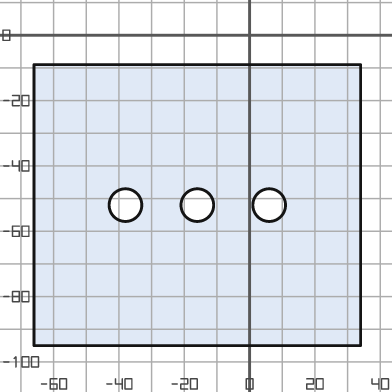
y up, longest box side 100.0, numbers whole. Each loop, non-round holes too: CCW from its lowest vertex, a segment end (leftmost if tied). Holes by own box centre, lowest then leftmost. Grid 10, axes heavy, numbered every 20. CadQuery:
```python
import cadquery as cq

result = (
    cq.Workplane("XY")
    .moveTo(-66.0, -95.0)
    .lineTo(34.0, -95.0)
    .lineTo(34.0, -9.0)
    .lineTo(-66.0, -9.0)
    .close()
    .moveTo(-38.0, -52.0)
    .circle(5.0)
    .moveTo(-16.0, -52.0)
    .circle(5.0)
    .moveTo(6.0, -52.0)
    .circle(5.0)
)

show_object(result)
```